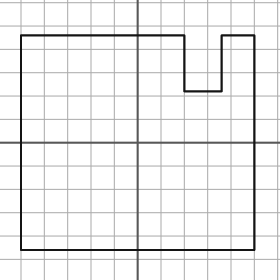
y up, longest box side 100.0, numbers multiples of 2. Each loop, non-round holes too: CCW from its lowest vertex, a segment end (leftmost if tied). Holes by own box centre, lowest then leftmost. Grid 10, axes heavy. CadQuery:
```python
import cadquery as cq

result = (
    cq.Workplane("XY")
    .moveTo(-50.0, -46.0)
    .lineTo(50.0, -46.0)
    .lineTo(50.0, 46.0)
    .lineTo(36.0, 46.0)
    .lineTo(36.0, 22.0)
    .lineTo(20.0, 22.0)
    .lineTo(20.0, 46.0)
    .lineTo(-50.0, 46.0)
    .close()
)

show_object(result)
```